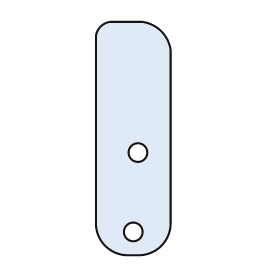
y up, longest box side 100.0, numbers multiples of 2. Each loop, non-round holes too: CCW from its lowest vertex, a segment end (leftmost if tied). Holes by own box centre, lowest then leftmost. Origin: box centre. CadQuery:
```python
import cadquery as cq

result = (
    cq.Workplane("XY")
    .moveTo(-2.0, -50.0)
    .lineTo(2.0, -50.0)
    .threePointArc((12.0, -46.0), (16.0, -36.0))
    .lineTo(16.0, 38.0)
    .threePointArc((12.0, 46.0), (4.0, 50.0))
    .lineTo(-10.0, 50.0)
    .threePointArc((-14.0, 48.0), (-16.0, 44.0))
    .lineTo(-16.0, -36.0)
    .threePointArc((-12.0, -46.0), (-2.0, -50.0))
    .close()
    .moveTo(0.0, -40.0)
    .circle(4.0)
    .moveTo(2.0, -6.0)
    .circle(4.0)
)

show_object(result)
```